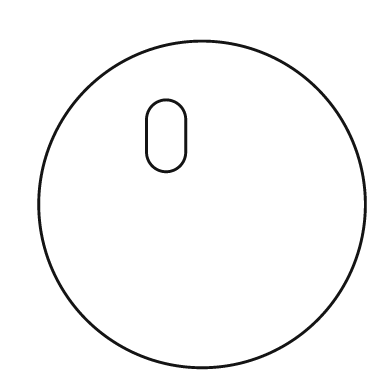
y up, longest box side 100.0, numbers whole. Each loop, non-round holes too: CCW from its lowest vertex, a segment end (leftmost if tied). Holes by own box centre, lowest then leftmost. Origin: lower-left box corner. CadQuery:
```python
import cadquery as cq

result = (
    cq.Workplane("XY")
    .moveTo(50.0, 50.0)
    .circle(50.0)
    .moveTo(33.0, 66.0)
    .threePointArc((39.0, 60.0), (45.0, 66.0))
    .lineTo(45.0, 76.0)
    .threePointArc((39.0, 82.0), (33.0, 76.0))
    .close()
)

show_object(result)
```